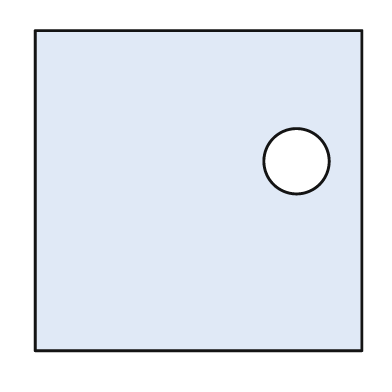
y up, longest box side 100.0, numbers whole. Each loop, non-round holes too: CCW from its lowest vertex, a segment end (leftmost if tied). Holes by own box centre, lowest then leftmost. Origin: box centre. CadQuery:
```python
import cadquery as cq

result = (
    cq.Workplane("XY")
    .moveTo(-50.0, -49.0)
    .lineTo(50.0, -49.0)
    .lineTo(50.0, 49.0)
    .lineTo(-50.0, 49.0)
    .close()
    .moveTo(30.0, 9.0)
    .circle(10.0)
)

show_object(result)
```